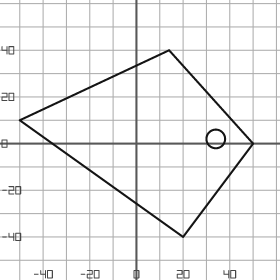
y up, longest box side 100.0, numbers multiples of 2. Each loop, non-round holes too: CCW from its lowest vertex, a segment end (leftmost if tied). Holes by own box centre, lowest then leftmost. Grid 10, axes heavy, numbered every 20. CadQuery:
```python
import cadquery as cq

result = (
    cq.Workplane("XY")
    .moveTo(20.0, -40.0)
    .lineTo(50.0, 0.0)
    .lineTo(14.0, 40.0)
    .lineTo(-50.0, 10.0)
    .close()
    .moveTo(34.0, 2.0)
    .circle(4.0)
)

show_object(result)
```